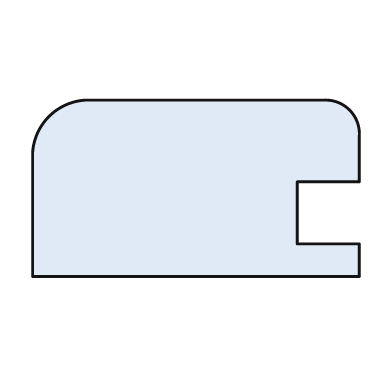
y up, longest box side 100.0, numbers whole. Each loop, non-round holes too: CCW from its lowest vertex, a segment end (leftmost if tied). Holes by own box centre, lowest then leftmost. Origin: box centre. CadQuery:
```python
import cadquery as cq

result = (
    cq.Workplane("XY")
    .moveTo(-50.0, -27.0)
    .lineTo(50.0, -27.0)
    .lineTo(50.0, -17.0)
    .lineTo(31.0, -17.0)
    .lineTo(31.0, 2.0)
    .lineTo(50.0, 2.0)
    .lineTo(50.0, 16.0)
    .threePointArc((47.0, 24.0), (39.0, 27.0))
    .lineTo(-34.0, 27.0)
    .threePointArc((-45.0, 22.0), (-50.0, 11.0))
    .close()
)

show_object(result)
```